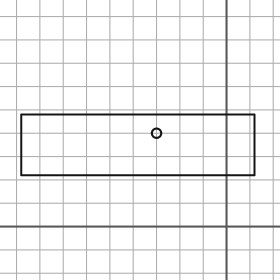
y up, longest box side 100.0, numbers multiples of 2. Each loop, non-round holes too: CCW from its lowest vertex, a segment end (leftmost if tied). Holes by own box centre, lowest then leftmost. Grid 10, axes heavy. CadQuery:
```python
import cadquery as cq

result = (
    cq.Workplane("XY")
    .moveTo(-88.0, 22.0)
    .lineTo(12.0, 22.0)
    .lineTo(12.0, 48.0)
    .lineTo(-88.0, 48.0)
    .close()
    .moveTo(-30.0, 40.0)
    .circle(2.0)
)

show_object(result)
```